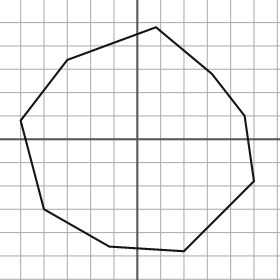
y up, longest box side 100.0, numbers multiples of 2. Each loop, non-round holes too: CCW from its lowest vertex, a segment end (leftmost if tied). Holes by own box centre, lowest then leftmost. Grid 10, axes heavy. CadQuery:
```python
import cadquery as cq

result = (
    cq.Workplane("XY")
    .moveTo(20.0, -48.0)
    .lineTo(50.0, -18.0)
    .lineTo(46.0, 10.0)
    .lineTo(32.0, 28.0)
    .lineTo(8.0, 48.0)
    .lineTo(-30.0, 34.0)
    .lineTo(-50.0, 8.0)
    .lineTo(-40.0, -30.0)
    .lineTo(-12.0, -46.0)
    .close()
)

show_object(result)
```